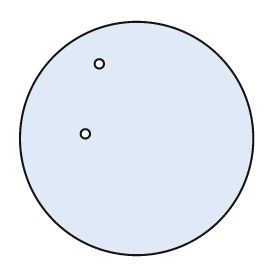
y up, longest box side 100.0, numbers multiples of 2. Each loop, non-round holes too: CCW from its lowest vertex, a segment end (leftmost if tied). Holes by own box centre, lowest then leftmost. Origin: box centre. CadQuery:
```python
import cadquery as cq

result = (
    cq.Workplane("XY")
    .moveTo(0.0, 0.0)
    .circle(50.0)
    .moveTo(-22.0, 2.0)
    .circle(2.0)
    .moveTo(-16.0, 32.0)
    .circle(2.0)
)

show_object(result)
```